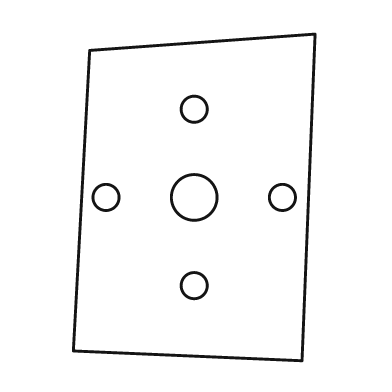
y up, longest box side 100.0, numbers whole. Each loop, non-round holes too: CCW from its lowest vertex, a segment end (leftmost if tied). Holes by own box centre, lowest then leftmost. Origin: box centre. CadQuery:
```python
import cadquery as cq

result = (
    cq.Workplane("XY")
    .moveTo(33.0, -50.0)
    .lineTo(37.0, 50.0)
    .lineTo(-32.0, 45.0)
    .lineTo(-37.0, -47.0)
    .close()
    .moveTo(0.0, -27.0)
    .circle(4.0)
    .moveTo(-27.0, 0.0)
    .circle(4.0)
    .moveTo(0.0, 0.0)
    .circle(7.0)
    .moveTo(27.0, 0.0)
    .circle(4.0)
    .moveTo(0.0, 27.0)
    .circle(4.0)
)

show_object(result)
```